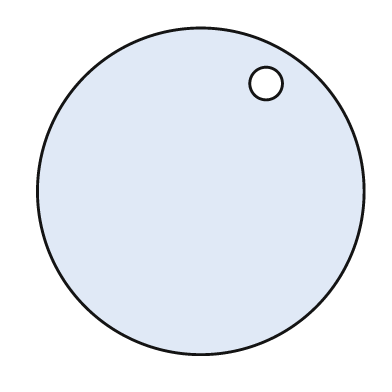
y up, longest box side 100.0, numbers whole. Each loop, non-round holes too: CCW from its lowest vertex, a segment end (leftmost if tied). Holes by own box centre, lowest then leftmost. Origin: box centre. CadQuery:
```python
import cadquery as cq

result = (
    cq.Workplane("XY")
    .moveTo(0.0, 0.0)
    .circle(50.0)
    .moveTo(20.0, 33.0)
    .circle(5.0)
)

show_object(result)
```